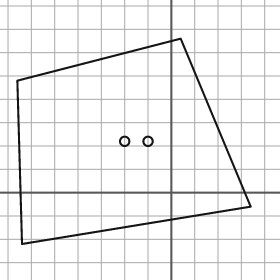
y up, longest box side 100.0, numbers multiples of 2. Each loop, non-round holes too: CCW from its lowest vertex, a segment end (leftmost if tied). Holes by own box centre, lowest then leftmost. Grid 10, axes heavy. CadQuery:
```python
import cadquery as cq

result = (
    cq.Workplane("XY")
    .moveTo(-64.0, -22.0)
    .lineTo(34.0, -6.0)
    .lineTo(4.0, 66.0)
    .lineTo(-66.0, 48.0)
    .close()
    .moveTo(-20.0, 22.0)
    .circle(2.0)
    .moveTo(-10.0, 22.0)
    .circle(2.0)
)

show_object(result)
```